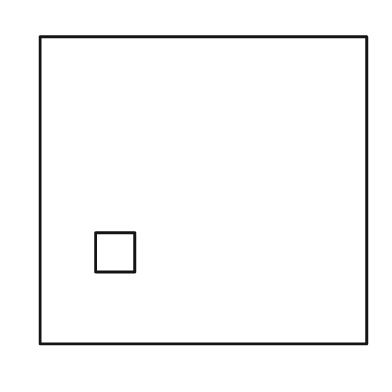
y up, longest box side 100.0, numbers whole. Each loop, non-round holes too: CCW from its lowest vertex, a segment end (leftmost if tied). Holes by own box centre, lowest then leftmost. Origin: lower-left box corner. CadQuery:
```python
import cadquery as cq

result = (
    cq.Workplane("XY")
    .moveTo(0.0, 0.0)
    .lineTo(100.0, 0.0)
    .lineTo(100.0, 94.0)
    .lineTo(0.0, 94.0)
    .close()
    .moveTo(17.0, 22.0)
    .lineTo(29.0, 22.0)
    .lineTo(29.0, 34.0)
    .lineTo(17.0, 34.0)
    .close()
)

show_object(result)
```